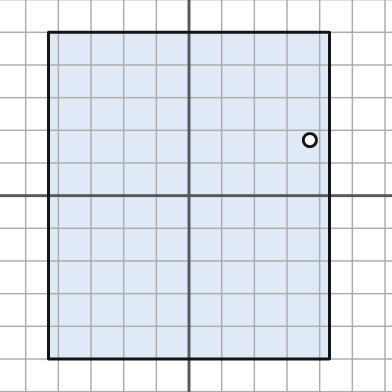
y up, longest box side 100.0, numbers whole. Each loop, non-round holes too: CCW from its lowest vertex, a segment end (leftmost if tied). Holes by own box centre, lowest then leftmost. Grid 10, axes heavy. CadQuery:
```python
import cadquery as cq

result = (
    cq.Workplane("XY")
    .moveTo(-43.0, -50.0)
    .lineTo(43.0, -50.0)
    .lineTo(43.0, 50.0)
    .lineTo(-43.0, 50.0)
    .close()
    .moveTo(37.0, 17.0)
    .circle(2.0)
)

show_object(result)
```